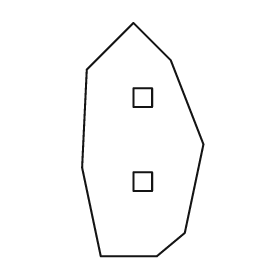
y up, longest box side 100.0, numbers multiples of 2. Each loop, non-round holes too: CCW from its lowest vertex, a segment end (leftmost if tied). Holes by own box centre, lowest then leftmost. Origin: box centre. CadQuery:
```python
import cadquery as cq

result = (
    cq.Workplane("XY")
    .moveTo(-18.0, -50.0)
    .lineTo(6.0, -50.0)
    .lineTo(18.0, -40.0)
    .lineTo(26.0, -2.0)
    .lineTo(12.0, 34.0)
    .lineTo(-4.0, 50.0)
    .lineTo(-24.0, 30.0)
    .lineTo(-26.0, -12.0)
    .close()
    .moveTo(-4.0, -22.0)
    .lineTo(4.0, -22.0)
    .lineTo(4.0, -14.0)
    .lineTo(-4.0, -14.0)
    .close()
    .moveTo(-4.0, 14.0)
    .lineTo(4.0, 14.0)
    .lineTo(4.0, 22.0)
    .lineTo(-4.0, 22.0)
    .close()
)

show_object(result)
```